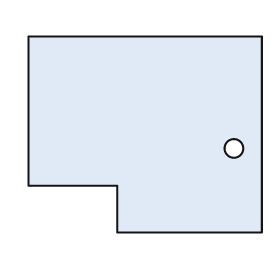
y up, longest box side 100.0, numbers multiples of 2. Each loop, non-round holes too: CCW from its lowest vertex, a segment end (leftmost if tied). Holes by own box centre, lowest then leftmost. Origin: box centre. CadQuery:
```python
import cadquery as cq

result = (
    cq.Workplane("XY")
    .moveTo(-12.0, -42.0)
    .lineTo(50.0, -42.0)
    .lineTo(50.0, 42.0)
    .lineTo(-50.0, 42.0)
    .lineTo(-50.0, -22.0)
    .lineTo(-12.0, -22.0)
    .close()
    .moveTo(38.0, -6.0)
    .circle(4.0)
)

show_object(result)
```